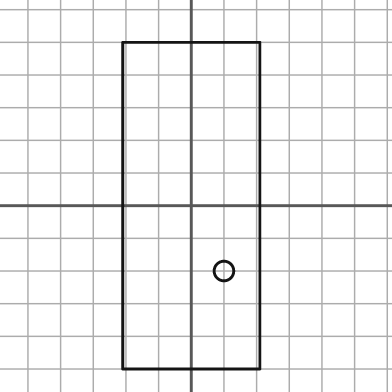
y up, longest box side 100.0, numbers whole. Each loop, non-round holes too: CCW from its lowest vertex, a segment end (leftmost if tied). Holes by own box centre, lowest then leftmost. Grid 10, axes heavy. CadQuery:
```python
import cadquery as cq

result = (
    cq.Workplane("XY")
    .moveTo(-21.0, -50.0)
    .lineTo(21.0, -50.0)
    .lineTo(21.0, 50.0)
    .lineTo(-21.0, 50.0)
    .close()
    .moveTo(10.0, -20.0)
    .circle(3.0)
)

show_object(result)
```